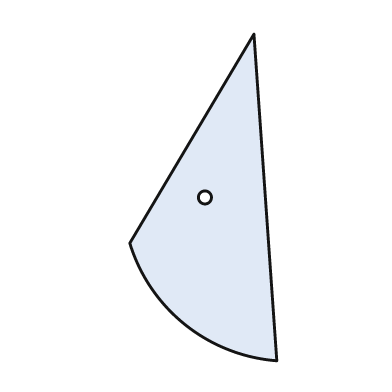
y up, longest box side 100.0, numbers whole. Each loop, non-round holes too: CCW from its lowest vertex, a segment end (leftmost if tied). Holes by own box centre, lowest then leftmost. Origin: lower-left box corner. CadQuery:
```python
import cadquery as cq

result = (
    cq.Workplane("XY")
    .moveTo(45.0, 0.0)
    .lineTo(38.0, 100.0)
    .lineTo(0.0, 36.0)
    .threePointArc((17.0, 11.0), (45.0, 0.0))
    .close()
    .moveTo(23.0, 50.0)
    .circle(2.0)
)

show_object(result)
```